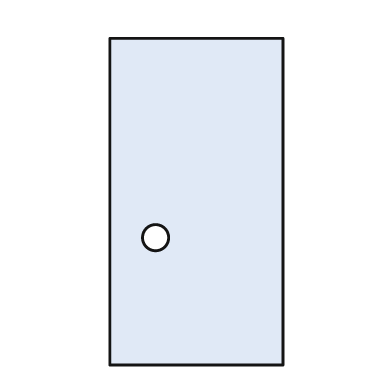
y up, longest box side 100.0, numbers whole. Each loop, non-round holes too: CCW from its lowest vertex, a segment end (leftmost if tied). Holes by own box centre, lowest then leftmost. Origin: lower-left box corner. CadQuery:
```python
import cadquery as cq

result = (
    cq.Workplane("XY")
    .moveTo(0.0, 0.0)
    .lineTo(53.0, 0.0)
    .lineTo(53.0, 100.0)
    .lineTo(0.0, 100.0)
    .close()
    .moveTo(14.0, 39.0)
    .circle(4.0)
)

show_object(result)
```